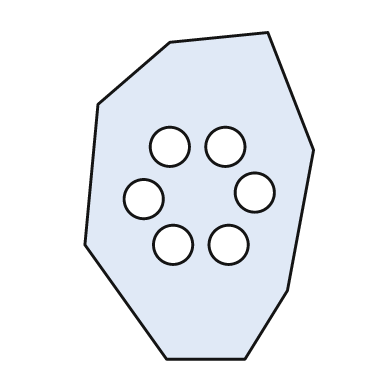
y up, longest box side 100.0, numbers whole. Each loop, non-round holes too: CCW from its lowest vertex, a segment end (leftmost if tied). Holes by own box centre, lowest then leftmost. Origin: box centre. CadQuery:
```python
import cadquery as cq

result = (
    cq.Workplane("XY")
    .moveTo(-10.0, -50.0)
    .lineTo(14.0, -50.0)
    .lineTo(27.0, -29.0)
    .lineTo(35.0, 14.0)
    .lineTo(21.0, 50.0)
    .lineTo(-9.0, 47.0)
    .lineTo(-31.0, 28.0)
    .lineTo(-35.0, -15.0)
    .close()
    .moveTo(-8.0, -15.0)
    .circle(6.0)
    .moveTo(9.0, -15.0)
    .circle(6.0)
    .moveTo(-17.0, -1.0)
    .circle(6.0)
    .moveTo(17.0, 1.0)
    .circle(6.0)
    .moveTo(-9.0, 15.0)
    .circle(6.0)
    .moveTo(8.0, 15.0)
    .circle(6.0)
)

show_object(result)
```